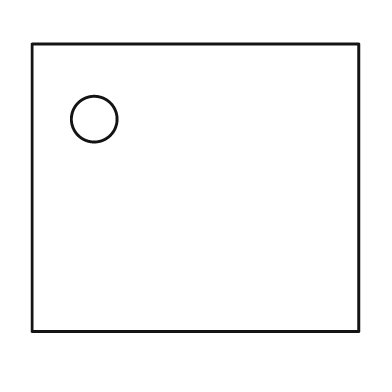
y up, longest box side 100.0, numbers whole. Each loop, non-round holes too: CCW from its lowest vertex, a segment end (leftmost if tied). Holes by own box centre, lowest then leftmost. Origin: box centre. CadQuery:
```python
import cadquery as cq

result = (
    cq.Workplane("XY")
    .moveTo(-50.0, -44.0)
    .lineTo(50.0, -44.0)
    .lineTo(50.0, 44.0)
    .lineTo(-50.0, 44.0)
    .close()
    .moveTo(-31.0, 21.0)
    .circle(7.0)
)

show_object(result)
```